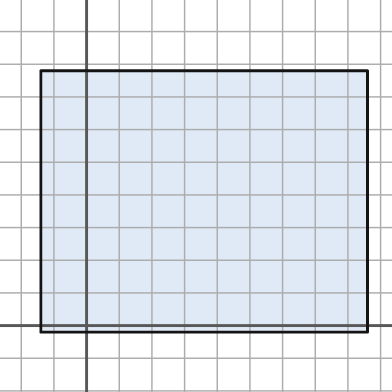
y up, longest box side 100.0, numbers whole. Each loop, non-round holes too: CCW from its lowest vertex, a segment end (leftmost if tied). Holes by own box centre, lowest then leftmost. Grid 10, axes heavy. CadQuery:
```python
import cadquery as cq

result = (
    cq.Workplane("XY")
    .moveTo(-14.0, -2.0)
    .lineTo(86.0, -2.0)
    .lineTo(86.0, 78.0)
    .lineTo(-14.0, 78.0)
    .close()
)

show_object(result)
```